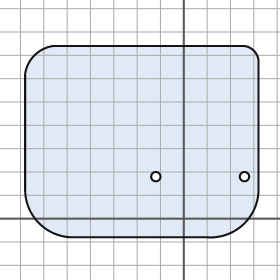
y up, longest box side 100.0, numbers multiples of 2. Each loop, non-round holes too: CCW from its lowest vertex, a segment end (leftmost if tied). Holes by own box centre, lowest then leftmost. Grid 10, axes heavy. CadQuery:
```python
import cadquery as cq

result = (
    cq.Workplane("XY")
    .moveTo(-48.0, -8.0)
    .lineTo(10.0, -8.0)
    .threePointArc((26.0, -2.0), (32.0, 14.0))
    .lineTo(32.0, 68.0)
    .threePointArc((30.0, 72.0), (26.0, 74.0))
    .lineTo(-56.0, 74.0)
    .threePointArc((-64.0, 70.0), (-68.0, 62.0))
    .lineTo(-68.0, 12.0)
    .threePointArc((-62.0, -2.0), (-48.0, -8.0))
    .close()
    .moveTo(-12.0, 18.0)
    .circle(2.0)
    .moveTo(26.0, 18.0)
    .circle(2.0)
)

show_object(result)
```